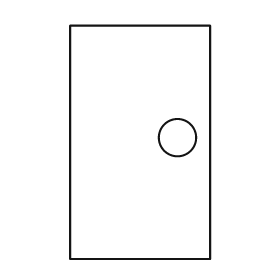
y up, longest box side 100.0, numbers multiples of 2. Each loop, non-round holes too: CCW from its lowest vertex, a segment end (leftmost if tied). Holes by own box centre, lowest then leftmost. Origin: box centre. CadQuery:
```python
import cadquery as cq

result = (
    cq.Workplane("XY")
    .moveTo(-30.0, -50.0)
    .lineTo(30.0, -50.0)
    .lineTo(30.0, 50.0)
    .lineTo(-30.0, 50.0)
    .close()
    .moveTo(16.0, 2.0)
    .circle(8.0)
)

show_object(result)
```